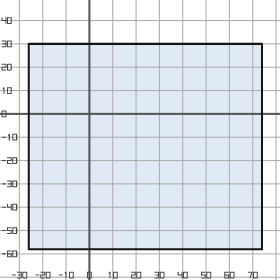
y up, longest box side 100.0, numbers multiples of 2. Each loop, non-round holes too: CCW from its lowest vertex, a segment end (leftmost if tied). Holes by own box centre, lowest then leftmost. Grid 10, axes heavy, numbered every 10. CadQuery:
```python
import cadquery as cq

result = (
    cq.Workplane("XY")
    .moveTo(-26.0, -58.0)
    .lineTo(74.0, -58.0)
    .lineTo(74.0, 30.0)
    .lineTo(-26.0, 30.0)
    .close()
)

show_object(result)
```